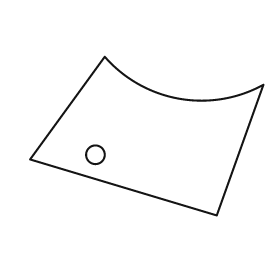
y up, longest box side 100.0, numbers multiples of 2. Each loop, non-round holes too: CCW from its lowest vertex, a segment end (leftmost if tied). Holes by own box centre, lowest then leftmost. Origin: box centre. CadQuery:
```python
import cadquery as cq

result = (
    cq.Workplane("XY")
    .moveTo(30.0, -34.0)
    .lineTo(50.0, 22.0)
    .threePointArc((14.0, 16.0), (-18.0, 34.0))
    .lineTo(-50.0, -10.0)
    .close()
    .moveTo(-22.0, -8.0)
    .circle(4.0)
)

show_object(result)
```